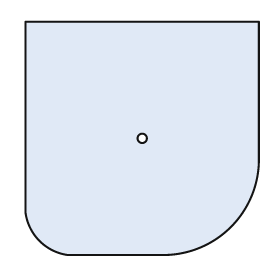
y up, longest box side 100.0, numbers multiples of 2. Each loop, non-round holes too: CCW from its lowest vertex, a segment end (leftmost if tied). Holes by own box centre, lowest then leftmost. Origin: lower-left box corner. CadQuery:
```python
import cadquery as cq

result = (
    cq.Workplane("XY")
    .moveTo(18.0, 0.0)
    .lineTo(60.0, 0.0)
    .threePointArc((88.0, 12.0), (100.0, 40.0))
    .lineTo(100.0, 100.0)
    .lineTo(0.0, 100.0)
    .lineTo(0.0, 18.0)
    .threePointArc((6.0, 6.0), (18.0, 0.0))
    .close()
    .moveTo(50.0, 50.0)
    .circle(2.0)
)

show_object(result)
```